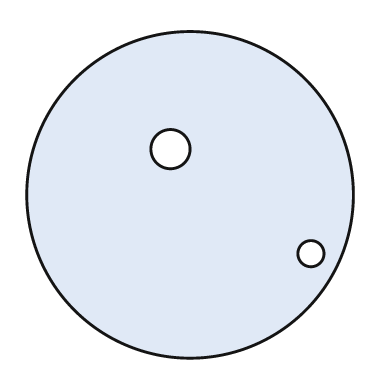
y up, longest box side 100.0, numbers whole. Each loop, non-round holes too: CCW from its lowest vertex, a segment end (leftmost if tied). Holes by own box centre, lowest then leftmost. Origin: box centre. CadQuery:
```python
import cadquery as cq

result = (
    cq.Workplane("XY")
    .moveTo(0.0, 0.0)
    .circle(50.0)
    .moveTo(37.0, -18.0)
    .circle(4.0)
    .moveTo(-6.0, 14.0)
    .circle(6.0)
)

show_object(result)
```